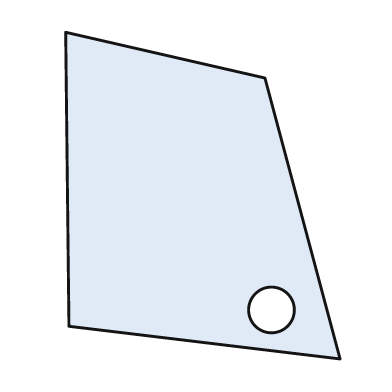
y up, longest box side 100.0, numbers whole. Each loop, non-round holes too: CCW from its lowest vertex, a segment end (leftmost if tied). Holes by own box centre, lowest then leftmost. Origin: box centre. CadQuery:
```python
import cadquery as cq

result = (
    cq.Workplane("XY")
    .moveTo(42.0, -50.0)
    .lineTo(19.0, 36.0)
    .lineTo(-42.0, 50.0)
    .lineTo(-41.0, -40.0)
    .close()
    .moveTo(21.0, -35.0)
    .circle(7.0)
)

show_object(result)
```